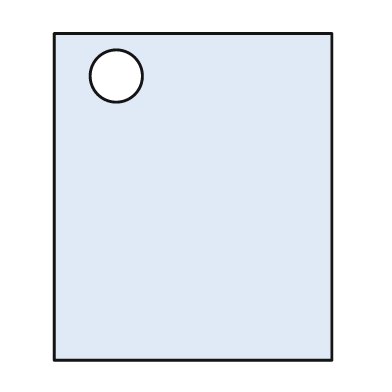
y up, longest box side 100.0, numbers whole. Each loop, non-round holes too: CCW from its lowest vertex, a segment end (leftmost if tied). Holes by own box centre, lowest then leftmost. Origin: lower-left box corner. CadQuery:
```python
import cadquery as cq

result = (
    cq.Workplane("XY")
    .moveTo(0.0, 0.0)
    .lineTo(85.0, 0.0)
    .lineTo(85.0, 100.0)
    .lineTo(0.0, 100.0)
    .close()
    .moveTo(19.0, 87.0)
    .circle(8.0)
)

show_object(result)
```